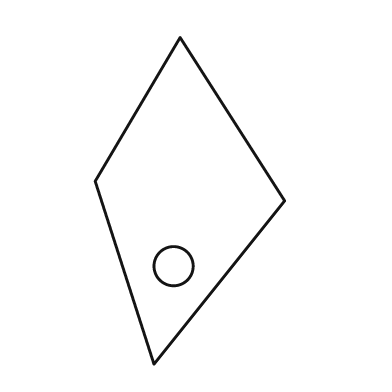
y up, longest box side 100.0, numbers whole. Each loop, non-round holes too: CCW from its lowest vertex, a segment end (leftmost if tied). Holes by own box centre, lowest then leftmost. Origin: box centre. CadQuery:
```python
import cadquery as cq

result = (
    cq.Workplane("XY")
    .moveTo(-11.0, -50.0)
    .lineTo(29.0, 0.0)
    .lineTo(-3.0, 50.0)
    .lineTo(-29.0, 6.0)
    .close()
    .moveTo(-5.0, -20.0)
    .circle(6.0)
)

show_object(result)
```